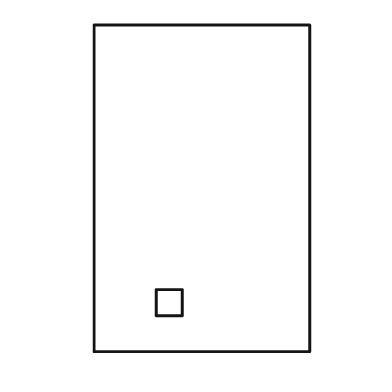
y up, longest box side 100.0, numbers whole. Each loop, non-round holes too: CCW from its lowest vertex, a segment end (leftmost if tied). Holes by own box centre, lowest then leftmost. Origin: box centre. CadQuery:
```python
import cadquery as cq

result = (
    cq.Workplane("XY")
    .moveTo(-33.0, -50.0)
    .lineTo(33.0, -50.0)
    .lineTo(33.0, 50.0)
    .lineTo(-33.0, 50.0)
    .close()
    .moveTo(-14.0, -39.0)
    .lineTo(-6.0, -39.0)
    .lineTo(-6.0, -31.0)
    .lineTo(-14.0, -31.0)
    .close()
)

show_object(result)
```